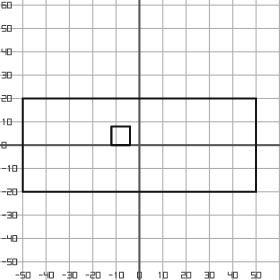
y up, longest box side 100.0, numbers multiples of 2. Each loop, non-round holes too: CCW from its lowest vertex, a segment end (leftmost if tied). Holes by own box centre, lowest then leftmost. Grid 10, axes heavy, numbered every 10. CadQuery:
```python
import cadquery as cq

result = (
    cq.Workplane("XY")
    .moveTo(-50.0, -20.0)
    .lineTo(50.0, -20.0)
    .lineTo(50.0, 20.0)
    .lineTo(-50.0, 20.0)
    .close()
    .moveTo(-12.0, 0.0)
    .lineTo(-4.0, 0.0)
    .lineTo(-4.0, 8.0)
    .lineTo(-12.0, 8.0)
    .close()
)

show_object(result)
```